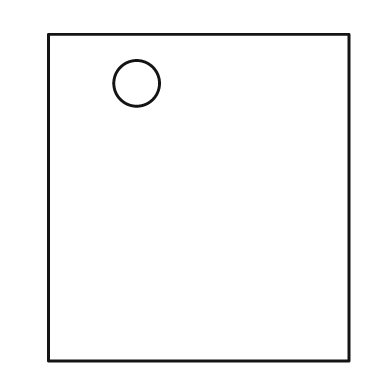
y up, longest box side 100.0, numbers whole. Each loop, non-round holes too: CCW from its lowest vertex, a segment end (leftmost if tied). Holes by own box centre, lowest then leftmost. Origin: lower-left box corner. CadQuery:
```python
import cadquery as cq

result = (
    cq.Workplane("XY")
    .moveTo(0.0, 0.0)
    .lineTo(92.0, 0.0)
    .lineTo(92.0, 100.0)
    .lineTo(0.0, 100.0)
    .close()
    .moveTo(27.0, 85.0)
    .circle(7.0)
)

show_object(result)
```